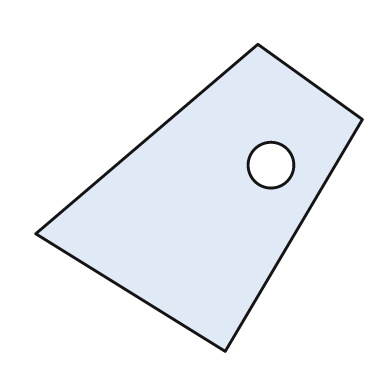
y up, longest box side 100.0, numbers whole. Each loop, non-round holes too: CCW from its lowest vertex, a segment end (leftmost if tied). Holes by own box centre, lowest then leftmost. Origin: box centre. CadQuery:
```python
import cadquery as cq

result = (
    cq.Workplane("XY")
    .moveTo(8.0, -47.0)
    .lineTo(50.0, 24.0)
    .lineTo(18.0, 47.0)
    .lineTo(-50.0, -11.0)
    .close()
    .moveTo(22.0, 10.0)
    .circle(7.0)
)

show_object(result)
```